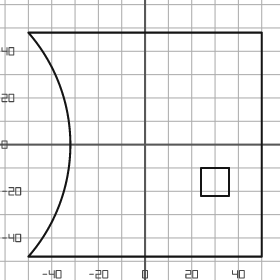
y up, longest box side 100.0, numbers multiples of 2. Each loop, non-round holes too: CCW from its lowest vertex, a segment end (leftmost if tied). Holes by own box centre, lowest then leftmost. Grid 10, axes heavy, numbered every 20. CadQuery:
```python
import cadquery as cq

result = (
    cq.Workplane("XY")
    .moveTo(-50.0, -48.0)
    .lineTo(50.0, -48.0)
    .lineTo(50.0, 48.0)
    .lineTo(-50.0, 48.0)
    .threePointArc((-32.0, 0.0), (-50.0, -48.0))
    .close()
    .moveTo(24.0, -22.0)
    .lineTo(36.0, -22.0)
    .lineTo(36.0, -10.0)
    .lineTo(24.0, -10.0)
    .close()
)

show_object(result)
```